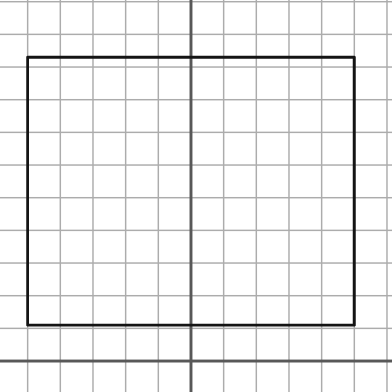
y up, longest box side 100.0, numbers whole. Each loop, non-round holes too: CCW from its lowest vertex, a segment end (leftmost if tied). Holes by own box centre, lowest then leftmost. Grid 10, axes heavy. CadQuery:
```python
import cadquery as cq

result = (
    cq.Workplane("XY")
    .moveTo(-50.0, 11.0)
    .lineTo(50.0, 11.0)
    .lineTo(50.0, 93.0)
    .lineTo(-50.0, 93.0)
    .close()
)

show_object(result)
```